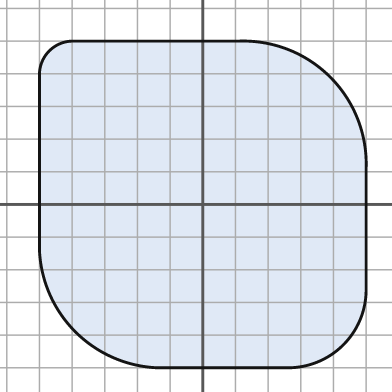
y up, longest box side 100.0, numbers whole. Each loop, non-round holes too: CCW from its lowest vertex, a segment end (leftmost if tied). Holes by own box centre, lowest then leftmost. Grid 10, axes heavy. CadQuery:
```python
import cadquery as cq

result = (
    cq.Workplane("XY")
    .moveTo(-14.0, -50.0)
    .lineTo(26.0, -50.0)
    .threePointArc((43.0, -43.0), (50.0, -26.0))
    .lineTo(50.0, 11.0)
    .threePointArc((39.0, 39.0), (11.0, 50.0))
    .lineTo(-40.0, 50.0)
    .threePointArc((-47.0, 47.0), (-50.0, 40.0))
    .lineTo(-50.0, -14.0)
    .threePointArc((-39.0, -39.0), (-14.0, -50.0))
    .close()
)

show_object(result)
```